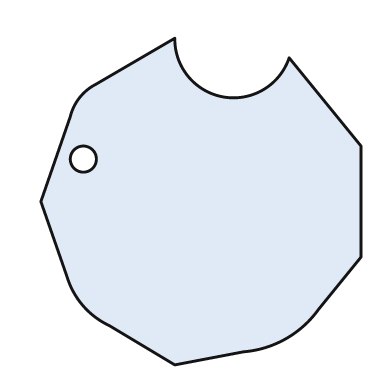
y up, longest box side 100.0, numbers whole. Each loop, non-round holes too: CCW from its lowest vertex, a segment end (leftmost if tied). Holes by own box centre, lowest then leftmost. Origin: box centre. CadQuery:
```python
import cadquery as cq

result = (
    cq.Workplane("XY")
    .moveTo(-8.0, -50.0)
    .lineTo(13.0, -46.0)
    .threePointArc((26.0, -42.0), (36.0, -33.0))
    .lineTo(49.0, -17.0)
    .lineTo(49.0, 17.0)
    .lineTo(27.0, 44.0)
    .threePointArc((7.0, 32.0), (-8.0, 50.0))
    .lineTo(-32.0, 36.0)
    .threePointArc((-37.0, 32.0), (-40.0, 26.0))
    .lineTo(-49.0, 0.0)
    .lineTo(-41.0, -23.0)
    .threePointArc((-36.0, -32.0), (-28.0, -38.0))
    .close()
    .moveTo(-36.0, 13.0)
    .circle(4.0)
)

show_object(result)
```